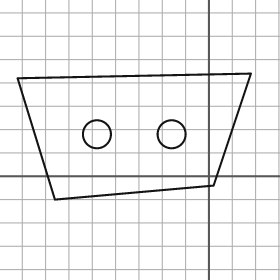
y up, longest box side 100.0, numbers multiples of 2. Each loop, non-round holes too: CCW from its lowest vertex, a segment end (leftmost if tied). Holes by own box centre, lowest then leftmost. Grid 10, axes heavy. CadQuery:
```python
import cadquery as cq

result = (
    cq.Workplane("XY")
    .moveTo(-66.0, -10.0)
    .lineTo(2.0, -4.0)
    .lineTo(18.0, 44.0)
    .lineTo(-82.0, 42.0)
    .close()
    .moveTo(-48.0, 18.0)
    .circle(6.0)
    .moveTo(-16.0, 18.0)
    .circle(6.0)
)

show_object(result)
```